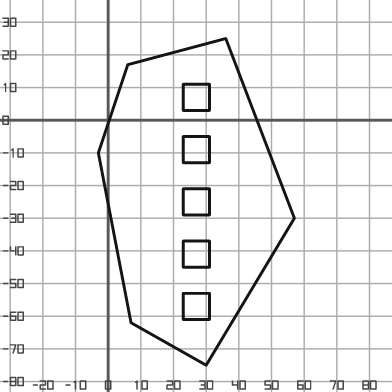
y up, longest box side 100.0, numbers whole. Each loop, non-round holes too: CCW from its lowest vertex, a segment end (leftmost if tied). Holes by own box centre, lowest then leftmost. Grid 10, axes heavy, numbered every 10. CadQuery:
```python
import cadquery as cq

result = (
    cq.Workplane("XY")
    .moveTo(30.0, -75.0)
    .lineTo(57.0, -30.0)
    .lineTo(36.0, 25.0)
    .lineTo(6.0, 17.0)
    .lineTo(-3.0, -10.0)
    .lineTo(7.0, -62.0)
    .close()
    .moveTo(23.0, -61.0)
    .lineTo(31.0, -61.0)
    .lineTo(31.0, -53.0)
    .lineTo(23.0, -53.0)
    .close()
    .moveTo(23.0, -45.0)
    .lineTo(31.0, -45.0)
    .lineTo(31.0, -37.0)
    .lineTo(23.0, -37.0)
    .close()
    .moveTo(23.0, -29.0)
    .lineTo(31.0, -29.0)
    .lineTo(31.0, -21.0)
    .lineTo(23.0, -21.0)
    .close()
    .moveTo(23.0, -13.0)
    .lineTo(31.0, -13.0)
    .lineTo(31.0, -5.0)
    .lineTo(23.0, -5.0)
    .close()
    .moveTo(23.0, 3.0)
    .lineTo(31.0, 3.0)
    .lineTo(31.0, 11.0)
    .lineTo(23.0, 11.0)
    .close()
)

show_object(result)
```